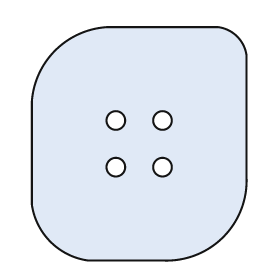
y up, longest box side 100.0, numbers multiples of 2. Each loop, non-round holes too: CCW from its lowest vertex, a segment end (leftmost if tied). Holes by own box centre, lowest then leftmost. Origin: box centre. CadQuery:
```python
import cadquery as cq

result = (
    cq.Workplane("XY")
    .moveTo(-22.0, -50.0)
    .lineTo(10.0, -50.0)
    .threePointArc((36.0, -40.0), (46.0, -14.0))
    .lineTo(46.0, 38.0)
    .threePointArc((42.0, 46.0), (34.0, 50.0))
    .lineTo(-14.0, 50.0)
    .threePointArc((-36.0, 40.0), (-46.0, 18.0))
    .lineTo(-46.0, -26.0)
    .threePointArc((-38.0, -42.0), (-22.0, -50.0))
    .close()
    .moveTo(-10.0, -10.0)
    .circle(4.0)
    .moveTo(10.0, -10.0)
    .circle(4.0)
    .moveTo(-10.0, 10.0)
    .circle(4.0)
    .moveTo(10.0, 10.0)
    .circle(4.0)
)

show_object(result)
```